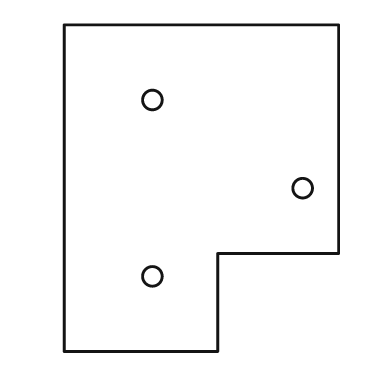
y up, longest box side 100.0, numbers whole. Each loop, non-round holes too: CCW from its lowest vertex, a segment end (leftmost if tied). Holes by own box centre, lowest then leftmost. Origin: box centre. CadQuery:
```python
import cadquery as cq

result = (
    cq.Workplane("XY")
    .moveTo(-42.0, -50.0)
    .lineTo(5.0, -50.0)
    .lineTo(5.0, -20.0)
    .lineTo(42.0, -20.0)
    .lineTo(42.0, 50.0)
    .lineTo(-42.0, 50.0)
    .close()
    .moveTo(-15.0, -27.0)
    .circle(3.0)
    .moveTo(31.0, 0.0)
    .circle(3.0)
    .moveTo(-15.0, 27.0)
    .circle(3.0)
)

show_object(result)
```